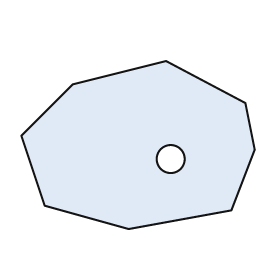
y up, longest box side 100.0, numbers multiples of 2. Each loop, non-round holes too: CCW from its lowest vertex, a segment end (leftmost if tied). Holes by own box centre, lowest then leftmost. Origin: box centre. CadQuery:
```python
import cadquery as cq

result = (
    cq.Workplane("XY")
    .moveTo(-4.0, -36.0)
    .lineTo(40.0, -28.0)
    .lineTo(50.0, -2.0)
    .lineTo(46.0, 18.0)
    .lineTo(12.0, 36.0)
    .lineTo(-28.0, 26.0)
    .lineTo(-50.0, 4.0)
    .lineTo(-40.0, -26.0)
    .close()
    .moveTo(14.0, -6.0)
    .circle(6.0)
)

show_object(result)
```